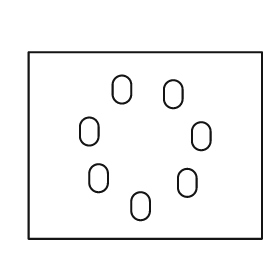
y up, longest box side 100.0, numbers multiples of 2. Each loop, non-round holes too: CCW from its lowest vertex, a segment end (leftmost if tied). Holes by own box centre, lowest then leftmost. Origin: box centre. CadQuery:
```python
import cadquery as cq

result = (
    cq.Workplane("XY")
    .moveTo(-50.0, -40.0)
    .lineTo(50.0, -40.0)
    .lineTo(50.0, 40.0)
    .lineTo(-50.0, 40.0)
    .close()
    .moveTo(-6.0, -28.0)
    .threePointArc((-2.0, -32.0), (2.0, -28.0))
    .lineTo(2.0, -24.0)
    .threePointArc((-2.0, -20.0), (-6.0, -24.0))
    .close()
    .moveTo(14.0, -18.0)
    .threePointArc((18.0, -22.0), (22.0, -18.0))
    .lineTo(22.0, -14.0)
    .threePointArc((18.0, -10.0), (14.0, -14.0))
    .close()
    .moveTo(-24.0, -16.0)
    .threePointArc((-20.0, -20.0), (-16.0, -16.0))
    .lineTo(-16.0, -12.0)
    .threePointArc((-20.0, -8.0), (-24.0, -12.0))
    .close()
    .moveTo(20.0, 2.0)
    .threePointArc((24.0, -2.0), (28.0, 2.0))
    .lineTo(28.0, 6.0)
    .threePointArc((24.0, 10.0), (20.0, 6.0))
    .close()
    .moveTo(-28.0, 4.0)
    .threePointArc((-24.0, 0.0), (-20.0, 4.0))
    .lineTo(-20.0, 8.0)
    .threePointArc((-24.0, 12.0), (-28.0, 8.0))
    .close()
    .moveTo(8.0, 20.0)
    .threePointArc((12.0, 16.0), (16.0, 20.0))
    .lineTo(16.0, 24.0)
    .threePointArc((12.0, 28.0), (8.0, 24.0))
    .close()
    .moveTo(-14.0, 22.0)
    .threePointArc((-10.0, 18.0), (-6.0, 22.0))
    .lineTo(-6.0, 26.0)
    .threePointArc((-10.0, 30.0), (-14.0, 26.0))
    .close()
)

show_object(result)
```